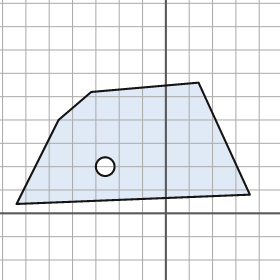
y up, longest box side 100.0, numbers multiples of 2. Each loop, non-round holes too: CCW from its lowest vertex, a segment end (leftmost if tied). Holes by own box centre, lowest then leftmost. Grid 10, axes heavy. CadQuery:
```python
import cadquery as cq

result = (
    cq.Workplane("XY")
    .moveTo(-64.0, 4.0)
    .lineTo(36.0, 8.0)
    .lineTo(14.0, 56.0)
    .lineTo(-32.0, 52.0)
    .lineTo(-46.0, 40.0)
    .close()
    .moveTo(-26.0, 20.0)
    .circle(4.0)
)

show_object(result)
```